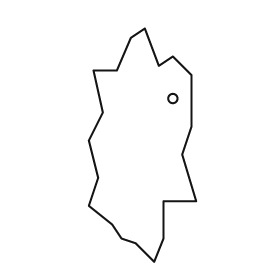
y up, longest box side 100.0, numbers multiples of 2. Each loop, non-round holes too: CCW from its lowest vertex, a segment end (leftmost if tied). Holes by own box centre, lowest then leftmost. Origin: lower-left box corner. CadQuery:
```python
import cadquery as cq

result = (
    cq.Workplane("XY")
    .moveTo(28.0, 0.0)
    .lineTo(32.0, 10.0)
    .lineTo(32.0, 26.0)
    .lineTo(46.0, 26.0)
    .lineTo(40.0, 46.0)
    .lineTo(44.0, 58.0)
    .lineTo(44.0, 80.0)
    .lineTo(36.0, 88.0)
    .lineTo(30.0, 84.0)
    .lineTo(24.0, 100.0)
    .lineTo(18.0, 96.0)
    .lineTo(12.0, 82.0)
    .lineTo(2.0, 82.0)
    .lineTo(6.0, 64.0)
    .lineTo(0.0, 52.0)
    .lineTo(4.0, 36.0)
    .lineTo(0.0, 24.0)
    .lineTo(10.0, 16.0)
    .lineTo(14.0, 10.0)
    .lineTo(20.0, 8.0)
    .close()
    .moveTo(36.0, 70.0)
    .circle(2.0)
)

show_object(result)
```